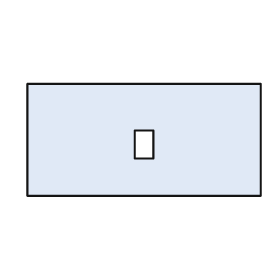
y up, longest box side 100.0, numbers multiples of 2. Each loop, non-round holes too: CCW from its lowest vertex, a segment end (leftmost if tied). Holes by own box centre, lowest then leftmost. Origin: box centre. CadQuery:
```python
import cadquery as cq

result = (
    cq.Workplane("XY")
    .moveTo(-50.0, -24.0)
    .lineTo(50.0, -24.0)
    .lineTo(50.0, 24.0)
    .lineTo(-50.0, 24.0)
    .close()
    .moveTo(-4.0, -8.0)
    .lineTo(4.0, -8.0)
    .lineTo(4.0, 4.0)
    .lineTo(-4.0, 4.0)
    .close()
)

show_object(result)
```